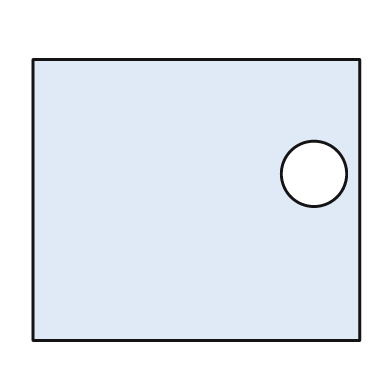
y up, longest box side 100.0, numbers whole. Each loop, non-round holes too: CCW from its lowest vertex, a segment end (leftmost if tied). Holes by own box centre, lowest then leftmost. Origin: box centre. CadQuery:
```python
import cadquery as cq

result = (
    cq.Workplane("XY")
    .moveTo(-50.0, -43.0)
    .lineTo(50.0, -43.0)
    .lineTo(50.0, 43.0)
    .lineTo(-50.0, 43.0)
    .close()
    .moveTo(36.0, 8.0)
    .circle(10.0)
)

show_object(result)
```